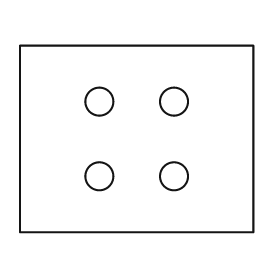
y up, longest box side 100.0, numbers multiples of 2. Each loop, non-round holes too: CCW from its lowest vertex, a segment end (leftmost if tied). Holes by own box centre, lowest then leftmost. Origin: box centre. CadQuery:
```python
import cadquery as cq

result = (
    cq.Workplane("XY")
    .moveTo(-50.0, -40.0)
    .lineTo(50.0, -40.0)
    .lineTo(50.0, 40.0)
    .lineTo(-50.0, 40.0)
    .close()
    .moveTo(-16.0, -16.0)
    .circle(6.0)
    .moveTo(16.0, -16.0)
    .circle(6.0)
    .moveTo(-16.0, 16.0)
    .circle(6.0)
    .moveTo(16.0, 16.0)
    .circle(6.0)
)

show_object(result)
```